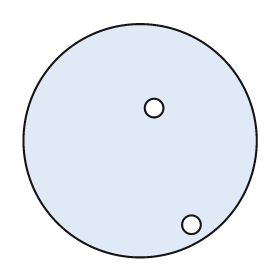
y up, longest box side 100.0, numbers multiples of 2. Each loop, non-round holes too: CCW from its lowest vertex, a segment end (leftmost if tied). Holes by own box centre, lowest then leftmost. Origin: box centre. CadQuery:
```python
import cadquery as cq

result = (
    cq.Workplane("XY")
    .moveTo(0.0, 0.0)
    .circle(50.0)
    .moveTo(22.0, -36.0)
    .circle(4.0)
    .moveTo(6.0, 14.0)
    .circle(4.0)
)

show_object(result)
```